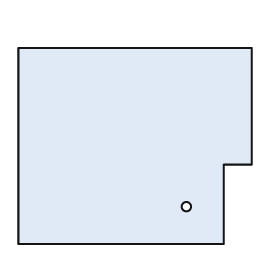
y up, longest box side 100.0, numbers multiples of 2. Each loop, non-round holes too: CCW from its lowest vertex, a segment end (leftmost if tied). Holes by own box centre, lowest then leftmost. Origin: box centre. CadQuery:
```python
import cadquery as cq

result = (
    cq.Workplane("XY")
    .moveTo(-50.0, -42.0)
    .lineTo(38.0, -42.0)
    .lineTo(38.0, -8.0)
    .lineTo(50.0, -8.0)
    .lineTo(50.0, 42.0)
    .lineTo(-50.0, 42.0)
    .close()
    .moveTo(22.0, -26.0)
    .circle(2.0)
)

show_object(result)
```